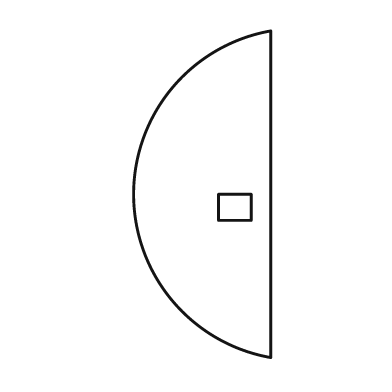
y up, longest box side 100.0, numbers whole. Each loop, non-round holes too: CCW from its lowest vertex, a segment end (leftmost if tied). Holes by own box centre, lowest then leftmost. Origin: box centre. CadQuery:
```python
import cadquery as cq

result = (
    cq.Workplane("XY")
    .moveTo(21.0, -50.0)
    .lineTo(21.0, 50.0)
    .threePointArc((-21.0, 0.0), (21.0, -50.0))
    .close()
    .moveTo(5.0, -8.0)
    .lineTo(15.0, -8.0)
    .lineTo(15.0, 0.0)
    .lineTo(5.0, 0.0)
    .close()
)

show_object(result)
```